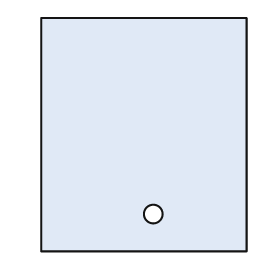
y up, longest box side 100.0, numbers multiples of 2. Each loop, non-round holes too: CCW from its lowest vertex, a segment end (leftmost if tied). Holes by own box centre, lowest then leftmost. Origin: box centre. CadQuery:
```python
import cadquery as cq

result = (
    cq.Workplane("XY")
    .moveTo(-44.0, -50.0)
    .lineTo(44.0, -50.0)
    .lineTo(44.0, 50.0)
    .lineTo(-44.0, 50.0)
    .close()
    .moveTo(4.0, -34.0)
    .circle(4.0)
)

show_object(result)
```